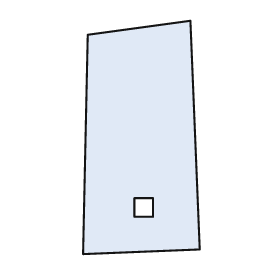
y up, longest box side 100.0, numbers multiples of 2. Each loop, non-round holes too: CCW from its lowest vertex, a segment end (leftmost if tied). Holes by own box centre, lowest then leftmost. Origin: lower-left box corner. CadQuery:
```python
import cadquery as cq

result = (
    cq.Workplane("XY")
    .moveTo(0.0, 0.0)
    .lineTo(50.0, 2.0)
    .lineTo(46.0, 100.0)
    .lineTo(2.0, 94.0)
    .close()
    .moveTo(22.0, 16.0)
    .lineTo(30.0, 16.0)
    .lineTo(30.0, 24.0)
    .lineTo(22.0, 24.0)
    .close()
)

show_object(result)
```